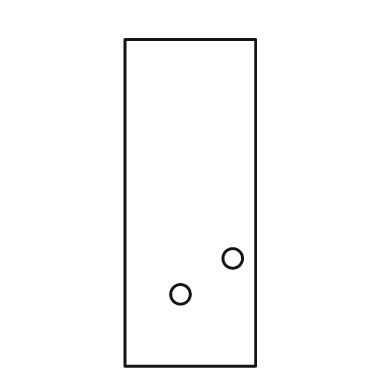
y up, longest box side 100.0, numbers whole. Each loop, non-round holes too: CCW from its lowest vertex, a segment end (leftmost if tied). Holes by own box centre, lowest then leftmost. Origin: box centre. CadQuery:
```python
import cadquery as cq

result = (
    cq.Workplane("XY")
    .moveTo(-20.0, -50.0)
    .lineTo(20.0, -50.0)
    .lineTo(20.0, 50.0)
    .lineTo(-20.0, 50.0)
    .close()
    .moveTo(-3.0, -28.0)
    .circle(3.0)
    .moveTo(13.0, -17.0)
    .circle(3.0)
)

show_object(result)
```